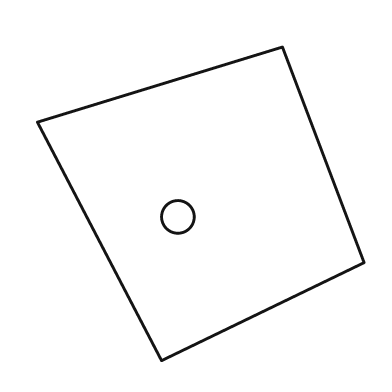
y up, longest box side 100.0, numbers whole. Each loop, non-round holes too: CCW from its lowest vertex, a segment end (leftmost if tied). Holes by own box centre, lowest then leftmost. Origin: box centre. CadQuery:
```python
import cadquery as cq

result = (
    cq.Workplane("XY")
    .moveTo(-12.0, -48.0)
    .lineTo(50.0, -18.0)
    .lineTo(25.0, 48.0)
    .lineTo(-50.0, 25.0)
    .close()
    .moveTo(-7.0, -4.0)
    .circle(5.0)
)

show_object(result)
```